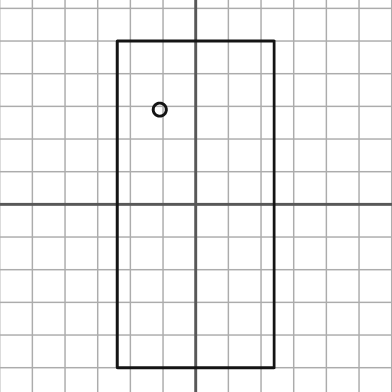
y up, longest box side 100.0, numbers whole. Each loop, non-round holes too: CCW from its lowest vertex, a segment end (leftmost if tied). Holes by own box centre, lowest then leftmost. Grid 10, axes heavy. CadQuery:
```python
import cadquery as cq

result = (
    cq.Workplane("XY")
    .moveTo(-24.0, -50.0)
    .lineTo(24.0, -50.0)
    .lineTo(24.0, 50.0)
    .lineTo(-24.0, 50.0)
    .close()
    .moveTo(-11.0, 29.0)
    .circle(2.0)
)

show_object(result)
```